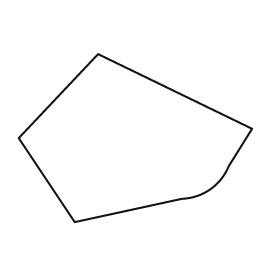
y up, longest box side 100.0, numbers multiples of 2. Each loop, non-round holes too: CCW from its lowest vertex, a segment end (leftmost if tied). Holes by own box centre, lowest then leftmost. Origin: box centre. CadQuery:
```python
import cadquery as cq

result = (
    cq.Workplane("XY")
    .moveTo(-26.0, -36.0)
    .lineTo(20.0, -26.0)
    .threePointArc((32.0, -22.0), (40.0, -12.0))
    .lineTo(50.0, 4.0)
    .lineTo(-16.0, 36.0)
    .lineTo(-50.0, 0.0)
    .close()
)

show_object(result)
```